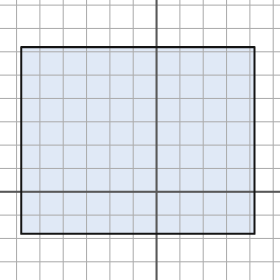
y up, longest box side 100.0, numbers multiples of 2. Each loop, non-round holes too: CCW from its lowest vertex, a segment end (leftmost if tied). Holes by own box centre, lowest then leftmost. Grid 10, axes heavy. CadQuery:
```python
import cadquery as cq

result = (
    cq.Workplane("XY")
    .moveTo(-58.0, -18.0)
    .lineTo(42.0, -18.0)
    .lineTo(42.0, 62.0)
    .lineTo(-58.0, 62.0)
    .close()
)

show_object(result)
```